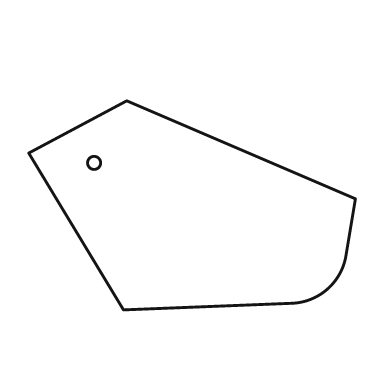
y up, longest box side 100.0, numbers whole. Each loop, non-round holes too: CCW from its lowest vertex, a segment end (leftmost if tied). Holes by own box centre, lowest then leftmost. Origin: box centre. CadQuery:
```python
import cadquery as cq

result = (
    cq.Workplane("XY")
    .moveTo(-21.0, -32.0)
    .lineTo(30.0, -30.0)
    .threePointArc((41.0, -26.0), (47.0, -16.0))
    .lineTo(50.0, 2.0)
    .lineTo(-20.0, 32.0)
    .lineTo(-50.0, 16.0)
    .close()
    .moveTo(-30.0, 13.0)
    .circle(2.0)
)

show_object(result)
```